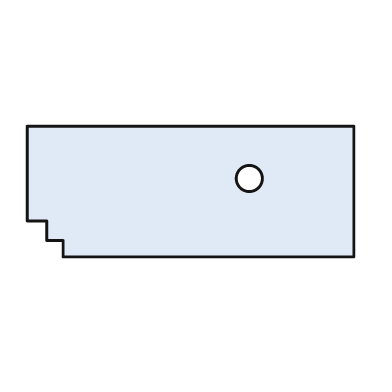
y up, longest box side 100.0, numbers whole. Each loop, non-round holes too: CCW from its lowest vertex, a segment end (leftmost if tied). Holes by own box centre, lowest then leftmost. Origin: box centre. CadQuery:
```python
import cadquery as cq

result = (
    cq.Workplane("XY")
    .moveTo(-39.0, -20.0)
    .lineTo(50.0, -20.0)
    .lineTo(50.0, 20.0)
    .lineTo(-50.0, 20.0)
    .lineTo(-50.0, -9.0)
    .lineTo(-44.0, -9.0)
    .lineTo(-44.0, -15.0)
    .lineTo(-39.0, -15.0)
    .close()
    .moveTo(18.0, 4.0)
    .circle(4.0)
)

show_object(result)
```